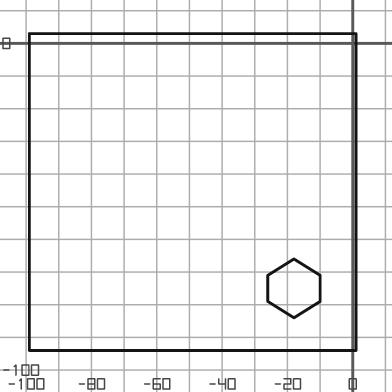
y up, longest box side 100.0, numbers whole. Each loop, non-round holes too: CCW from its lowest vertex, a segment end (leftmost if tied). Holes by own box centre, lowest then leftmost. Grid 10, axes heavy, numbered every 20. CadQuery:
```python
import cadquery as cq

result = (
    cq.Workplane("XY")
    .moveTo(-99.0, -94.0)
    .lineTo(1.0, -94.0)
    .lineTo(1.0, 3.0)
    .lineTo(-99.0, 3.0)
    .close()
    .moveTo(-18.0, -84.0)
    .lineTo(-10.0, -79.0)
    .lineTo(-10.0, -71.0)
    .lineTo(-18.0, -66.0)
    .lineTo(-26.0, -71.0)
    .lineTo(-26.0, -79.0)
    .close()
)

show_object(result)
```